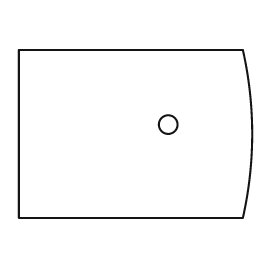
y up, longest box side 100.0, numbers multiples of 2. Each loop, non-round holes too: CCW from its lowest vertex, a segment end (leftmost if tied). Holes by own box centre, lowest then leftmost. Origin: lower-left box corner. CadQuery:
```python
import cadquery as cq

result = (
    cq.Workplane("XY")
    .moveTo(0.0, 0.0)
    .lineTo(96.0, 0.0)
    .threePointArc((100.0, 36.0), (96.0, 72.0))
    .lineTo(0.0, 72.0)
    .close()
    .moveTo(64.0, 40.0)
    .circle(4.0)
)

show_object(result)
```